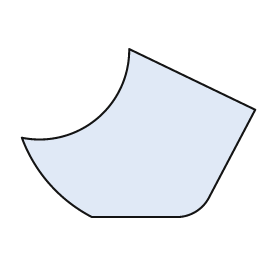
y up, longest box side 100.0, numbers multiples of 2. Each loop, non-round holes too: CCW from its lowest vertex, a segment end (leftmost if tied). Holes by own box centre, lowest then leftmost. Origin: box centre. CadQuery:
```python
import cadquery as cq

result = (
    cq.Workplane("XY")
    .moveTo(-20.0, -36.0)
    .lineTo(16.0, -36.0)
    .threePointArc((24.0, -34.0), (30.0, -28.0))
    .lineTo(50.0, 10.0)
    .lineTo(-4.0, 36.0)
    .threePointArc((-18.0, 6.0), (-50.0, -2.0))
    .threePointArc((-38.0, -22.0), (-20.0, -36.0))
    .close()
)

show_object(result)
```